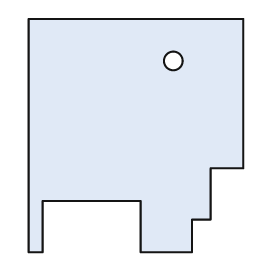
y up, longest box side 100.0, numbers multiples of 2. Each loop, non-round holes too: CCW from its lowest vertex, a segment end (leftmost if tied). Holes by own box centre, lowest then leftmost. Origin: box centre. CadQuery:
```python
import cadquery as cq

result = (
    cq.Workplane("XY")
    .moveTo(-46.0, -50.0)
    .lineTo(-40.0, -50.0)
    .lineTo(-40.0, -28.0)
    .lineTo(2.0, -28.0)
    .lineTo(2.0, -50.0)
    .lineTo(24.0, -50.0)
    .lineTo(24.0, -36.0)
    .lineTo(32.0, -36.0)
    .lineTo(32.0, -14.0)
    .lineTo(46.0, -14.0)
    .lineTo(46.0, 50.0)
    .lineTo(-46.0, 50.0)
    .close()
    .moveTo(16.0, 32.0)
    .circle(4.0)
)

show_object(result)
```